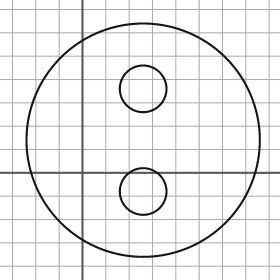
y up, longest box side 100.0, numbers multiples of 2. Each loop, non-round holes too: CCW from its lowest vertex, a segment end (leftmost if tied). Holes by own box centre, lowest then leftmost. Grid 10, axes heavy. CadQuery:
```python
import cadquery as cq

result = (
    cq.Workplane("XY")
    .moveTo(26.0, 14.0)
    .circle(50.0)
    .moveTo(26.0, -8.0)
    .circle(10.0)
    .moveTo(26.0, 36.0)
    .circle(10.0)
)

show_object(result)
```